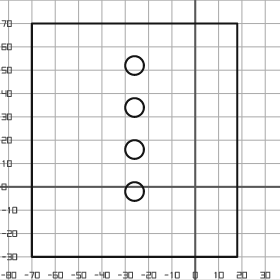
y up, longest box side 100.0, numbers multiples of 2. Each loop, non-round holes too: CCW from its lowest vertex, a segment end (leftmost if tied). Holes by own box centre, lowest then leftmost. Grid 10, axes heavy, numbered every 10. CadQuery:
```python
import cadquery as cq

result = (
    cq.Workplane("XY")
    .moveTo(-70.0, -30.0)
    .lineTo(18.0, -30.0)
    .lineTo(18.0, 70.0)
    .lineTo(-70.0, 70.0)
    .close()
    .moveTo(-26.0, -2.0)
    .circle(4.0)
    .moveTo(-26.0, 16.0)
    .circle(4.0)
    .moveTo(-26.0, 34.0)
    .circle(4.0)
    .moveTo(-26.0, 52.0)
    .circle(4.0)
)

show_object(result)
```